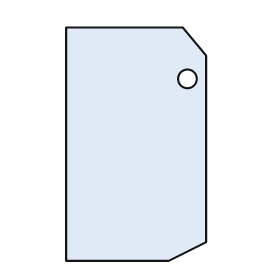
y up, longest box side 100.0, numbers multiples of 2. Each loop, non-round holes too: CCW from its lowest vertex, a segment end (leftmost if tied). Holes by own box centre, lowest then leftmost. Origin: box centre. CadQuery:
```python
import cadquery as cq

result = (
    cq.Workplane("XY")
    .moveTo(-30.0, -50.0)
    .lineTo(14.0, -50.0)
    .lineTo(30.0, -42.0)
    .lineTo(30.0, 38.0)
    .lineTo(20.0, 50.0)
    .lineTo(-30.0, 50.0)
    .close()
    .moveTo(22.0, 28.0)
    .circle(4.0)
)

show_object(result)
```